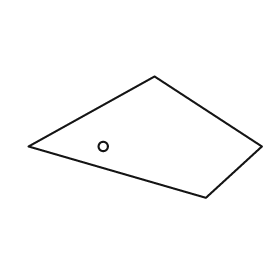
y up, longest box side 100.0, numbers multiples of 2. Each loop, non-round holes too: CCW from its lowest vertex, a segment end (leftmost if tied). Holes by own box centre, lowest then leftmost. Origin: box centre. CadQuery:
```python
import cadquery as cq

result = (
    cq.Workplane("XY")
    .moveTo(26.0, -26.0)
    .lineTo(50.0, -4.0)
    .lineTo(4.0, 26.0)
    .lineTo(-50.0, -4.0)
    .close()
    .moveTo(-18.0, -4.0)
    .circle(2.0)
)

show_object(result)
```